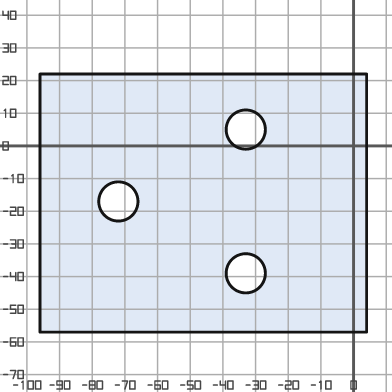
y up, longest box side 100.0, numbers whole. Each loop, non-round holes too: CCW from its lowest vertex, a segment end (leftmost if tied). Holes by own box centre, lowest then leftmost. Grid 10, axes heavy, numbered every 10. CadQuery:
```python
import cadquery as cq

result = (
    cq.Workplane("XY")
    .moveTo(-96.0, -57.0)
    .lineTo(4.0, -57.0)
    .lineTo(4.0, 22.0)
    .lineTo(-96.0, 22.0)
    .close()
    .moveTo(-33.0, -39.0)
    .circle(6.0)
    .moveTo(-72.0, -17.0)
    .circle(6.0)
    .moveTo(-33.0, 5.0)
    .circle(6.0)
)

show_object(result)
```